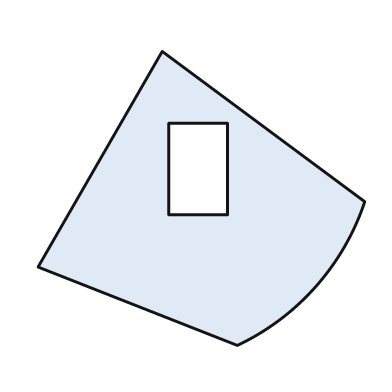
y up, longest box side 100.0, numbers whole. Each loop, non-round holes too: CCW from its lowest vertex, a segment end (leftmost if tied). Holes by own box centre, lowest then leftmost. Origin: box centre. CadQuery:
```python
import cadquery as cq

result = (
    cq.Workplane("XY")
    .moveTo(11.0, -45.0)
    .threePointArc((35.0, -27.0), (50.0, -1.0))
    .lineTo(-12.0, 45.0)
    .lineTo(-50.0, -21.0)
    .close()
    .moveTo(-10.0, -5.0)
    .lineTo(8.0, -5.0)
    .lineTo(8.0, 23.0)
    .lineTo(-10.0, 23.0)
    .close()
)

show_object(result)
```